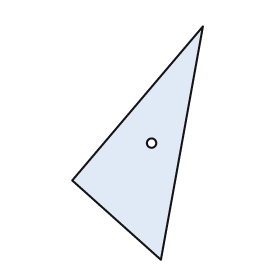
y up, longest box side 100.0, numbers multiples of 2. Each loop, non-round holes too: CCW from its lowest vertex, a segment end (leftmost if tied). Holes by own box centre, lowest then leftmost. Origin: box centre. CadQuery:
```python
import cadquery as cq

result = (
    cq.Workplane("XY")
    .moveTo(10.0, -50.0)
    .lineTo(28.0, 50.0)
    .lineTo(-28.0, -16.0)
    .close()
    .moveTo(6.0, 0.0)
    .circle(2.0)
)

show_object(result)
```